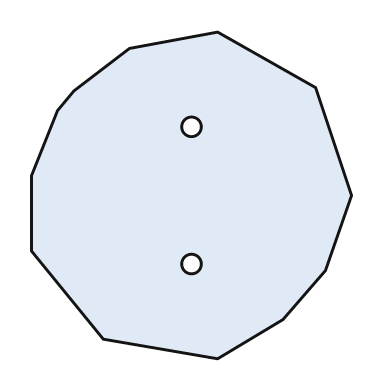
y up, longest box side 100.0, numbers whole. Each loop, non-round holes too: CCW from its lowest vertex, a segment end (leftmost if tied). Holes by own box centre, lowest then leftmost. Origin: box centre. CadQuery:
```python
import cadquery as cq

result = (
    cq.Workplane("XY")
    .moveTo(8.0, -50.0)
    .lineTo(28.0, -38.0)
    .lineTo(41.0, -23.0)
    .lineTo(49.0, 0.0)
    .lineTo(38.0, 33.0)
    .lineTo(8.0, 50.0)
    .lineTo(-19.0, 45.0)
    .lineTo(-36.0, 32.0)
    .lineTo(-41.0, 26.0)
    .lineTo(-49.0, 6.0)
    .lineTo(-49.0, -17.0)
    .lineTo(-27.0, -44.0)
    .close()
    .moveTo(0.0, -21.0)
    .circle(3.0)
    .moveTo(0.0, 21.0)
    .circle(3.0)
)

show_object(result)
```